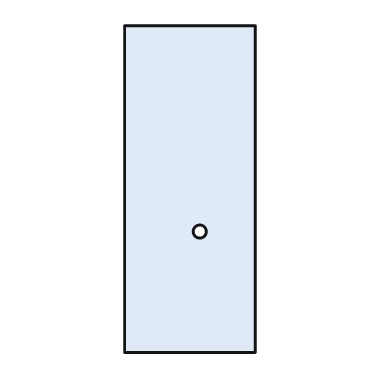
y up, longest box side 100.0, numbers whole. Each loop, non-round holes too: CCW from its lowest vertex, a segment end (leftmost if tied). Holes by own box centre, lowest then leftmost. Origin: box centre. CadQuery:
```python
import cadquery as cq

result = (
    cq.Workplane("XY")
    .moveTo(-20.0, -50.0)
    .lineTo(20.0, -50.0)
    .lineTo(20.0, 50.0)
    .lineTo(-20.0, 50.0)
    .close()
    .moveTo(3.0, -13.0)
    .circle(2.0)
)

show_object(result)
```